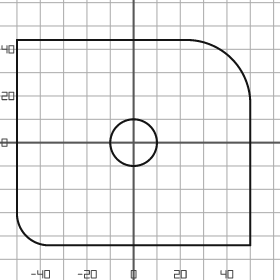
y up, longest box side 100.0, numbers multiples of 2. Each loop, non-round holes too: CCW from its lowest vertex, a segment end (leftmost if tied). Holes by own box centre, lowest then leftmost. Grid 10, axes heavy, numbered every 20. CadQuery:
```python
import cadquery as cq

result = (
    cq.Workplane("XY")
    .moveTo(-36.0, -44.0)
    .lineTo(50.0, -44.0)
    .lineTo(50.0, 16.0)
    .threePointArc((42.0, 36.0), (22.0, 44.0))
    .lineTo(-50.0, 44.0)
    .lineTo(-50.0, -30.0)
    .threePointArc((-46.0, -40.0), (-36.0, -44.0))
    .close()
    .moveTo(0.0, 0.0)
    .circle(10.0)
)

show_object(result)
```